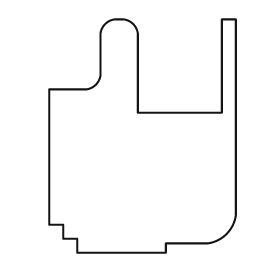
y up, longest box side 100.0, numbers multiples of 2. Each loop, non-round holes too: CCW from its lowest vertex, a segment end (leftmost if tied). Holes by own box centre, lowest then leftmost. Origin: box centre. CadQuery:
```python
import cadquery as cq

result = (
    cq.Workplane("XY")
    .moveTo(-28.0, -50.0)
    .lineTo(10.0, -50.0)
    .lineTo(10.0, -46.0)
    .lineTo(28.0, -46.0)
    .threePointArc((36.0, -42.0), (40.0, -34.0))
    .lineTo(40.0, 50.0)
    .lineTo(34.0, 50.0)
    .lineTo(34.0, 10.0)
    .lineTo(-2.0, 10.0)
    .lineTo(-2.0, 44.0)
    .threePointArc((-4.0, 48.0), (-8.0, 50.0))
    .lineTo(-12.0, 50.0)
    .threePointArc((-16.0, 48.0), (-18.0, 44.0))
    .lineTo(-18.0, 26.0)
    .threePointArc((-20.0, 22.0), (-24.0, 20.0))
    .lineTo(-40.0, 20.0)
    .lineTo(-40.0, -38.0)
    .lineTo(-34.0, -38.0)
    .lineTo(-34.0, -44.0)
    .lineTo(-28.0, -44.0)
    .close()
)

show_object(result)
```